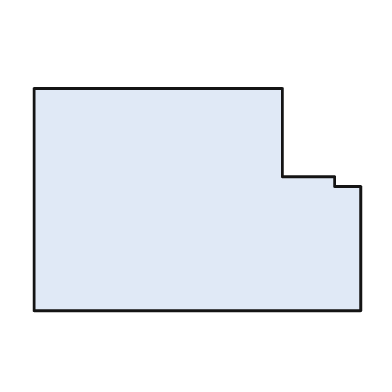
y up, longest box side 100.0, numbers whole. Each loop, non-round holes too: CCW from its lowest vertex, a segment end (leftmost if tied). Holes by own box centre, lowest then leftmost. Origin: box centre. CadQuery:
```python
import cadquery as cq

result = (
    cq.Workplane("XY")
    .moveTo(-50.0, -34.0)
    .lineTo(50.0, -34.0)
    .lineTo(50.0, 4.0)
    .lineTo(42.0, 4.0)
    .lineTo(42.0, 7.0)
    .lineTo(26.0, 7.0)
    .lineTo(26.0, 34.0)
    .lineTo(-50.0, 34.0)
    .close()
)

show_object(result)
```